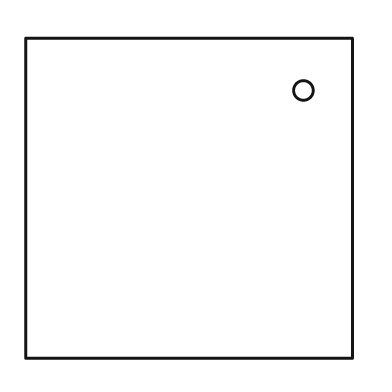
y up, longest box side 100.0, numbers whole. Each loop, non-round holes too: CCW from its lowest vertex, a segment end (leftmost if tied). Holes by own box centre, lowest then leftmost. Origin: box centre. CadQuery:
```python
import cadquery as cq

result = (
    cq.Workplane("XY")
    .moveTo(-50.0, -49.0)
    .lineTo(50.0, -49.0)
    .lineTo(50.0, 49.0)
    .lineTo(-50.0, 49.0)
    .close()
    .moveTo(35.0, 33.0)
    .circle(3.0)
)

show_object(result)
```